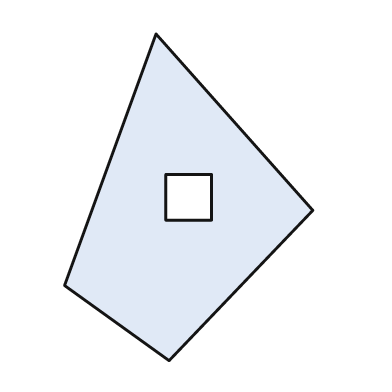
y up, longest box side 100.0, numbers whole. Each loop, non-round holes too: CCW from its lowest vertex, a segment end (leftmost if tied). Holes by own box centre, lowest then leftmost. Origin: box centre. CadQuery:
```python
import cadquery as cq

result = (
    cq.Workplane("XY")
    .moveTo(-6.0, -50.0)
    .lineTo(38.0, -4.0)
    .lineTo(-10.0, 50.0)
    .lineTo(-38.0, -27.0)
    .close()
    .moveTo(-7.0, -7.0)
    .lineTo(7.0, -7.0)
    .lineTo(7.0, 7.0)
    .lineTo(-7.0, 7.0)
    .close()
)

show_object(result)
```